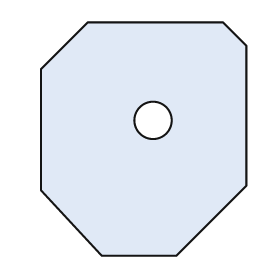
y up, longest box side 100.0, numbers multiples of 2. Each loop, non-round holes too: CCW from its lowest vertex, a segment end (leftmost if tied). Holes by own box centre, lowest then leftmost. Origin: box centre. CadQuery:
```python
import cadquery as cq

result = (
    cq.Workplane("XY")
    .moveTo(-18.0, -50.0)
    .lineTo(14.0, -50.0)
    .lineTo(44.0, -20.0)
    .lineTo(44.0, 40.0)
    .lineTo(34.0, 50.0)
    .lineTo(-24.0, 50.0)
    .lineTo(-44.0, 30.0)
    .lineTo(-44.0, -22.0)
    .close()
    .moveTo(4.0, 8.0)
    .circle(8.0)
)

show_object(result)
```